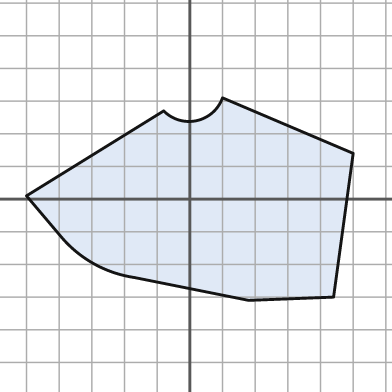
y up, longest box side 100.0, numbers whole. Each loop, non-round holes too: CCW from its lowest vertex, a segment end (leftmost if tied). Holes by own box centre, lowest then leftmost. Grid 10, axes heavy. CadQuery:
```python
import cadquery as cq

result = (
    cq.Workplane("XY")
    .moveTo(18.0, -31.0)
    .lineTo(44.0, -30.0)
    .lineTo(50.0, 14.0)
    .lineTo(10.0, 31.0)
    .threePointArc((2.0, 24.0), (-8.0, 27.0))
    .lineTo(-50.0, 1.0)
    .lineTo(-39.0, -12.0)
    .threePointArc((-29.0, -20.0), (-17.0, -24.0))
    .close()
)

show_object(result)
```